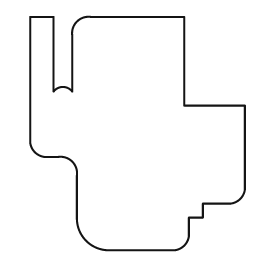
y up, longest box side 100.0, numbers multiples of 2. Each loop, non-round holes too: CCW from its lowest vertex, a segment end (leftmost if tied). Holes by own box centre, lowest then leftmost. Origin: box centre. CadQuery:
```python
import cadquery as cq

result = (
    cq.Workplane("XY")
    .moveTo(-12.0, -50.0)
    .lineTo(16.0, -50.0)
    .threePointArc((20.0, -48.0), (22.0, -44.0))
    .lineTo(22.0, -36.0)
    .lineTo(28.0, -36.0)
    .lineTo(28.0, -30.0)
    .lineTo(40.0, -30.0)
    .threePointArc((44.0, -28.0), (46.0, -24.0))
    .lineTo(46.0, 12.0)
    .lineTo(20.0, 12.0)
    .lineTo(20.0, 50.0)
    .lineTo(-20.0, 50.0)
    .threePointArc((-26.0, 48.0), (-28.0, 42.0))
    .lineTo(-28.0, 18.0)
    .threePointArc((-32.0, 20.0), (-36.0, 18.0))
    .lineTo(-36.0, 50.0)
    .lineTo(-46.0, 50.0)
    .lineTo(-46.0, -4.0)
    .threePointArc((-44.0, -8.0), (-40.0, -10.0))
    .lineTo(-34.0, -10.0)
    .threePointArc((-28.0, -12.0), (-26.0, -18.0))
    .lineTo(-26.0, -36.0)
    .threePointArc((-22.0, -46.0), (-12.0, -50.0))
    .close()
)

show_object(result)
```